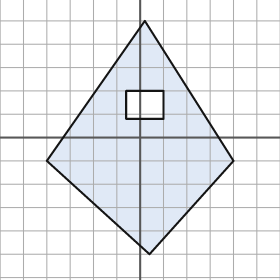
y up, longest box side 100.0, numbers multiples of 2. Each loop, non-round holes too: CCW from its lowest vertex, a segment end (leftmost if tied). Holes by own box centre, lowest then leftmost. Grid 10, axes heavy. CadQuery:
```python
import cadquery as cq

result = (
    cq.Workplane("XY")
    .moveTo(4.0, -50.0)
    .lineTo(40.0, -10.0)
    .lineTo(2.0, 50.0)
    .lineTo(-40.0, -10.0)
    .close()
    .moveTo(-6.0, 8.0)
    .lineTo(10.0, 8.0)
    .lineTo(10.0, 20.0)
    .lineTo(-6.0, 20.0)
    .close()
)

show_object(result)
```